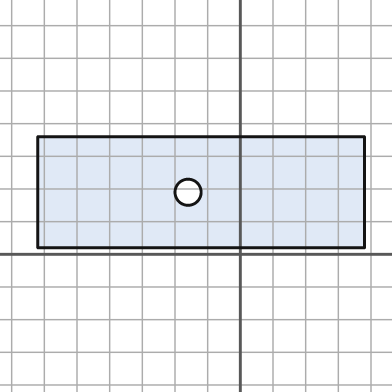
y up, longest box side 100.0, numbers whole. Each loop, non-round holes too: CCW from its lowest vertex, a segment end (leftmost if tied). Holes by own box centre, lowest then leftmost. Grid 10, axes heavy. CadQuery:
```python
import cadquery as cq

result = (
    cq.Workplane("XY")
    .moveTo(-62.0, 2.0)
    .lineTo(38.0, 2.0)
    .lineTo(38.0, 36.0)
    .lineTo(-62.0, 36.0)
    .close()
    .moveTo(-16.0, 19.0)
    .circle(4.0)
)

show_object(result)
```